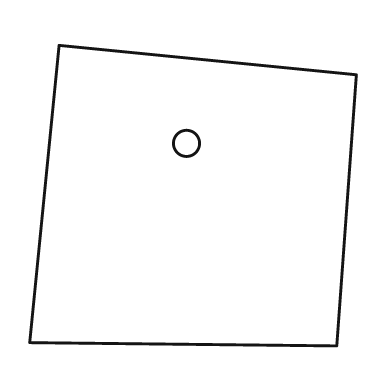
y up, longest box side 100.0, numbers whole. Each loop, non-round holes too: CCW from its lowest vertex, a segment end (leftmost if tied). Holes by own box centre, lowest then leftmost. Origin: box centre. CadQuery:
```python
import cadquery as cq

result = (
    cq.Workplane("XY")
    .moveTo(44.0, -46.0)
    .lineTo(50.0, 37.0)
    .lineTo(-41.0, 46.0)
    .lineTo(-50.0, -45.0)
    .close()
    .moveTo(-2.0, 16.0)
    .circle(4.0)
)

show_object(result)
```